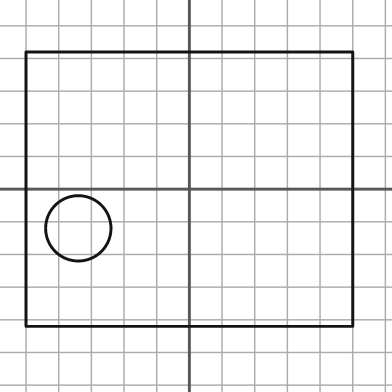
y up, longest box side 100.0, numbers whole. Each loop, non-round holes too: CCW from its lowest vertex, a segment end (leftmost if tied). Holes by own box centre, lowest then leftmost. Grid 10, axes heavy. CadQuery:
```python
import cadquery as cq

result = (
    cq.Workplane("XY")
    .moveTo(-50.0, -42.0)
    .lineTo(50.0, -42.0)
    .lineTo(50.0, 42.0)
    .lineTo(-50.0, 42.0)
    .close()
    .moveTo(-34.0, -12.0)
    .circle(10.0)
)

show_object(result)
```